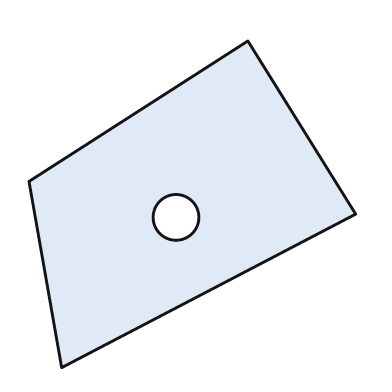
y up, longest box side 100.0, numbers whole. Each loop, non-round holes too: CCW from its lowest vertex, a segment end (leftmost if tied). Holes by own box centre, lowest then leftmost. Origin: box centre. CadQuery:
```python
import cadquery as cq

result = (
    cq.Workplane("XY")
    .moveTo(-40.0, -50.0)
    .lineTo(50.0, -3.0)
    .lineTo(17.0, 50.0)
    .lineTo(-50.0, 7.0)
    .close()
    .moveTo(-5.0, -4.0)
    .circle(7.0)
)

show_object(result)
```